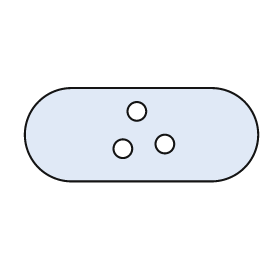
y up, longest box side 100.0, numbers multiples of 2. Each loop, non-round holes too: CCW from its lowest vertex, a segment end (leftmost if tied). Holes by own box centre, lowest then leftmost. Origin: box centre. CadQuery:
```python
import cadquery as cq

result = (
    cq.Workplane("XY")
    .moveTo(-30.0, -20.0)
    .lineTo(30.0, -20.0)
    .threePointArc((50.0, 0.0), (30.0, 20.0))
    .lineTo(-30.0, 20.0)
    .threePointArc((-50.0, 0.0), (-30.0, -20.0))
    .close()
    .moveTo(-8.0, -6.0)
    .circle(4.0)
    .moveTo(10.0, -4.0)
    .circle(4.0)
    .moveTo(-2.0, 10.0)
    .circle(4.0)
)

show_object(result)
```